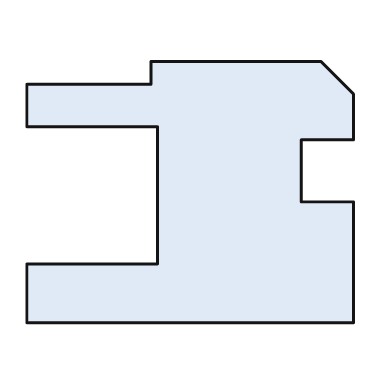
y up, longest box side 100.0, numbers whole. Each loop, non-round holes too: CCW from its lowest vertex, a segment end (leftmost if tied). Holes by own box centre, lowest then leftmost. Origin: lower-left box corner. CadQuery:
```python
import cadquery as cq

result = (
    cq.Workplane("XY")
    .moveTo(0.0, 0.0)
    .lineTo(100.0, 0.0)
    .lineTo(100.0, 37.0)
    .lineTo(84.0, 37.0)
    .lineTo(84.0, 56.0)
    .lineTo(100.0, 56.0)
    .lineTo(100.0, 70.0)
    .lineTo(90.0, 80.0)
    .lineTo(38.0, 80.0)
    .lineTo(38.0, 73.0)
    .lineTo(0.0, 73.0)
    .lineTo(0.0, 60.0)
    .lineTo(40.0, 60.0)
    .lineTo(40.0, 18.0)
    .lineTo(0.0, 18.0)
    .close()
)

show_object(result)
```